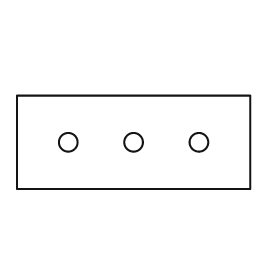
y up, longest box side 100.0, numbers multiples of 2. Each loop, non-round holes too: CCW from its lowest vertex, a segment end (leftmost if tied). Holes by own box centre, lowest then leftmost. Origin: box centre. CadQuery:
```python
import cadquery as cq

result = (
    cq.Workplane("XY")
    .moveTo(-50.0, -20.0)
    .lineTo(50.0, -20.0)
    .lineTo(50.0, 20.0)
    .lineTo(-50.0, 20.0)
    .close()
    .moveTo(-28.0, 0.0)
    .circle(4.0)
    .moveTo(0.0, 0.0)
    .circle(4.0)
    .moveTo(28.0, 0.0)
    .circle(4.0)
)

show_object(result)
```